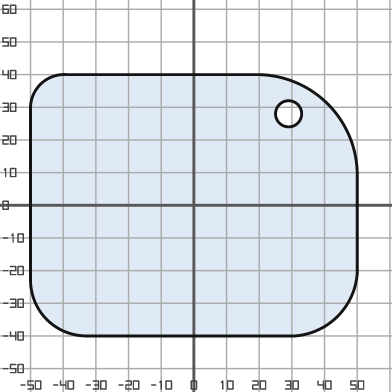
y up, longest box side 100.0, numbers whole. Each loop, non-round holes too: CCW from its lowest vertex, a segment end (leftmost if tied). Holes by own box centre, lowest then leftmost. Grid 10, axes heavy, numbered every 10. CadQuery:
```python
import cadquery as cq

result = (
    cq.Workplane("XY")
    .moveTo(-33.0, -40.0)
    .lineTo(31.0, -40.0)
    .threePointArc((44.0, -34.0), (50.0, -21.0))
    .lineTo(50.0, 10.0)
    .threePointArc((41.0, 31.0), (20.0, 40.0))
    .lineTo(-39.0, 40.0)
    .threePointArc((-47.0, 37.0), (-50.0, 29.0))
    .lineTo(-50.0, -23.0)
    .threePointArc((-45.0, -35.0), (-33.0, -40.0))
    .close()
    .moveTo(29.0, 28.0)
    .circle(4.0)
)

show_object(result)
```